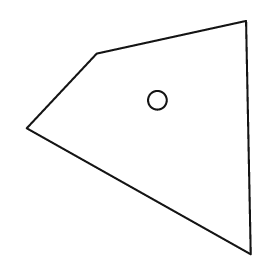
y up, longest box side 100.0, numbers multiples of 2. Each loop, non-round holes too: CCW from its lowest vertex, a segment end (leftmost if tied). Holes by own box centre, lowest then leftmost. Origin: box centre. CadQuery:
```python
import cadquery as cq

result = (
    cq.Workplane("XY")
    .moveTo(48.0, -50.0)
    .lineTo(46.0, 50.0)
    .lineTo(-18.0, 36.0)
    .lineTo(-48.0, 4.0)
    .close()
    .moveTo(8.0, 16.0)
    .circle(4.0)
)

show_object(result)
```